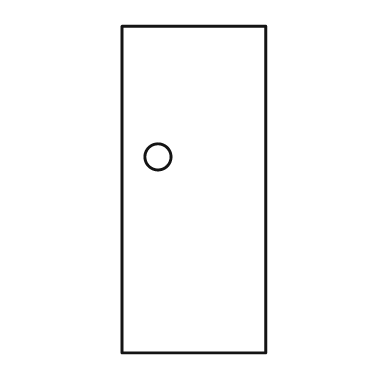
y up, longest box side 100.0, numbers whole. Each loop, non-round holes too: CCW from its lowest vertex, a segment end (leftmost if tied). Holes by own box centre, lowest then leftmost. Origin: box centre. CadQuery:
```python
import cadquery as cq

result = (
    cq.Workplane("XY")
    .moveTo(-22.0, -50.0)
    .lineTo(22.0, -50.0)
    .lineTo(22.0, 50.0)
    .lineTo(-22.0, 50.0)
    .close()
    .moveTo(-11.0, 10.0)
    .circle(4.0)
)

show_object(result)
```